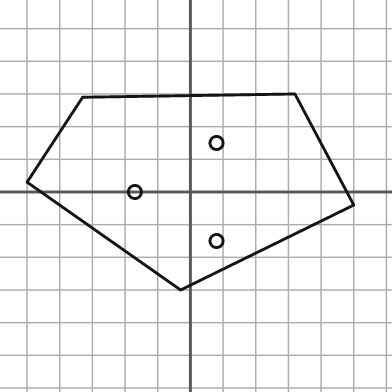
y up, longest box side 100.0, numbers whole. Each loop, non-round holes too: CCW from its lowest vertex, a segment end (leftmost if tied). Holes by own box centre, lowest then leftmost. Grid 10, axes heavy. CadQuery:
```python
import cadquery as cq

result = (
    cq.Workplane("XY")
    .moveTo(-3.0, -30.0)
    .lineTo(50.0, -4.0)
    .lineTo(32.0, 30.0)
    .lineTo(-33.0, 29.0)
    .lineTo(-50.0, 3.0)
    .close()
    .moveTo(8.0, -15.0)
    .circle(2.0)
    .moveTo(-17.0, 0.0)
    .circle(2.0)
    .moveTo(8.0, 15.0)
    .circle(2.0)
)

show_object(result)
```